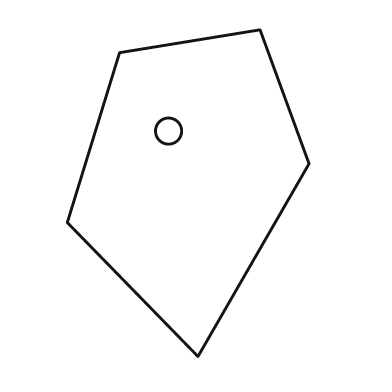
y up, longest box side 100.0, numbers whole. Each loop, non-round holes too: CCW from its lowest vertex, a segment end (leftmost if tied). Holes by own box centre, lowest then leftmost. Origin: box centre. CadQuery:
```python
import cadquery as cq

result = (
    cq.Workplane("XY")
    .moveTo(3.0, -50.0)
    .lineTo(37.0, 9.0)
    .lineTo(22.0, 50.0)
    .lineTo(-21.0, 43.0)
    .lineTo(-37.0, -9.0)
    .close()
    .moveTo(-6.0, 19.0)
    .circle(4.0)
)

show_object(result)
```